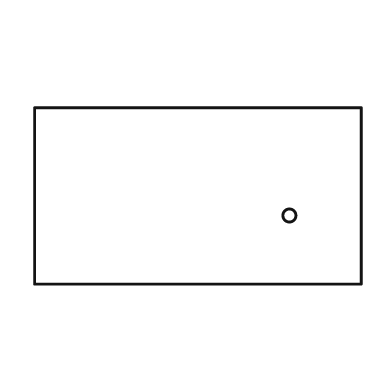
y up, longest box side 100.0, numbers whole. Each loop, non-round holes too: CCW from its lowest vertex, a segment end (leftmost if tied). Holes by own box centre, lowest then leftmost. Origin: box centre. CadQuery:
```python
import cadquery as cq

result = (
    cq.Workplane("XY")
    .moveTo(-50.0, -27.0)
    .lineTo(50.0, -27.0)
    .lineTo(50.0, 27.0)
    .lineTo(-50.0, 27.0)
    .close()
    .moveTo(28.0, -6.0)
    .circle(2.0)
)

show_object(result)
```